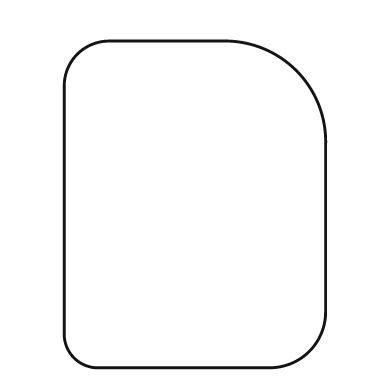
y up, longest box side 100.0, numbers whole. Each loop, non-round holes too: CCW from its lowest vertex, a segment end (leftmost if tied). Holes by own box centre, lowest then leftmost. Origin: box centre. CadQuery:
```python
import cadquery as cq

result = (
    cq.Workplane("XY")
    .moveTo(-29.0, -50.0)
    .lineTo(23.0, -50.0)
    .threePointArc((35.0, -45.0), (40.0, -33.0))
    .lineTo(40.0, 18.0)
    .threePointArc((31.0, 41.0), (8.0, 50.0))
    .lineTo(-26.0, 50.0)
    .threePointArc((-36.0, 46.0), (-40.0, 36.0))
    .lineTo(-40.0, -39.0)
    .threePointArc((-37.0, -47.0), (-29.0, -50.0))
    .close()
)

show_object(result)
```